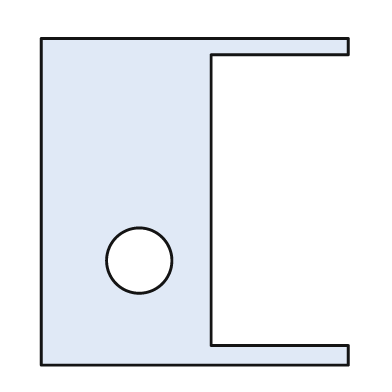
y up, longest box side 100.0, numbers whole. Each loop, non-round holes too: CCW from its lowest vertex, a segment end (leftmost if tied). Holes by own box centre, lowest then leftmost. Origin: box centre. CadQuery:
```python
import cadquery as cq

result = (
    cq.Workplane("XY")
    .moveTo(-47.0, -50.0)
    .lineTo(47.0, -50.0)
    .lineTo(47.0, -44.0)
    .lineTo(5.0, -44.0)
    .lineTo(5.0, 45.0)
    .lineTo(47.0, 45.0)
    .lineTo(47.0, 50.0)
    .lineTo(-47.0, 50.0)
    .close()
    .moveTo(-17.0, -18.0)
    .circle(10.0)
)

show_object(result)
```